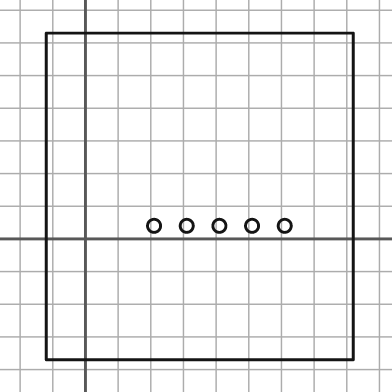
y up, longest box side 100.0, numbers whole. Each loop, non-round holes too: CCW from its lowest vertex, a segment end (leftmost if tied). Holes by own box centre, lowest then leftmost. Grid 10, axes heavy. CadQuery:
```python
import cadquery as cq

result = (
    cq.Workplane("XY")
    .moveTo(-12.0, -37.0)
    .lineTo(82.0, -37.0)
    .lineTo(82.0, 63.0)
    .lineTo(-12.0, 63.0)
    .close()
    .moveTo(21.0, 4.0)
    .circle(2.0)
    .moveTo(31.0, 4.0)
    .circle(2.0)
    .moveTo(41.0, 4.0)
    .circle(2.0)
    .moveTo(51.0, 4.0)
    .circle(2.0)
    .moveTo(61.0, 4.0)
    .circle(2.0)
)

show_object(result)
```